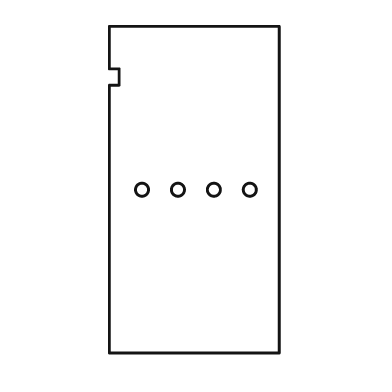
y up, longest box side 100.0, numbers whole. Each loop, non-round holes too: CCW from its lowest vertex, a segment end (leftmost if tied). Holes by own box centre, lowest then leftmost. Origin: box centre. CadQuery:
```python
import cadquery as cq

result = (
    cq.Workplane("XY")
    .moveTo(-26.0, -50.0)
    .lineTo(26.0, -50.0)
    .lineTo(26.0, 50.0)
    .lineTo(-26.0, 50.0)
    .lineTo(-26.0, 37.0)
    .lineTo(-23.0, 37.0)
    .lineTo(-23.0, 32.0)
    .lineTo(-26.0, 32.0)
    .close()
    .moveTo(-16.0, 0.0)
    .circle(2.0)
    .moveTo(-5.0, 0.0)
    .circle(2.0)
    .moveTo(6.0, 0.0)
    .circle(2.0)
    .moveTo(17.0, 0.0)
    .circle(2.0)
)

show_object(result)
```